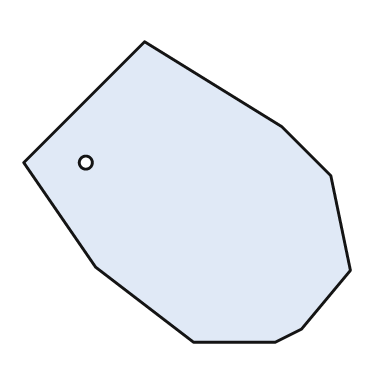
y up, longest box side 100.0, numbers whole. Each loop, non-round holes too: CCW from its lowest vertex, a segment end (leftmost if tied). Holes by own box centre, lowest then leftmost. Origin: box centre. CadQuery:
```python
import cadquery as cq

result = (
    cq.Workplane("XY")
    .moveTo(2.0, -46.0)
    .lineTo(27.0, -46.0)
    .lineTo(35.0, -42.0)
    .lineTo(50.0, -24.0)
    .lineTo(44.0, 5.0)
    .lineTo(29.0, 20.0)
    .lineTo(-13.0, 46.0)
    .lineTo(-50.0, 9.0)
    .lineTo(-28.0, -23.0)
    .close()
    .moveTo(-31.0, 9.0)
    .circle(2.0)
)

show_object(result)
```